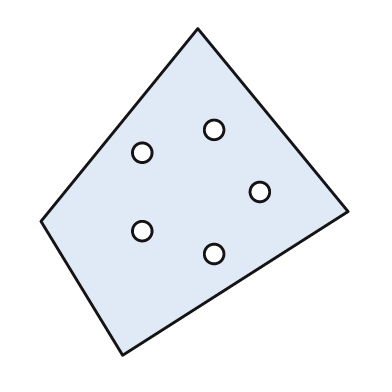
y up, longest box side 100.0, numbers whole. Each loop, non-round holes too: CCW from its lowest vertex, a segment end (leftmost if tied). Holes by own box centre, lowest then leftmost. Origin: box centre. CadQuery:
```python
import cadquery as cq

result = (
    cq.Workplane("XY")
    .moveTo(-22.0, -50.0)
    .lineTo(47.0, -6.0)
    .lineTo(1.0, 50.0)
    .lineTo(-47.0, -9.0)
    .close()
    .moveTo(6.0, -19.0)
    .circle(3.0)
    .moveTo(-16.0, -12.0)
    .circle(3.0)
    .moveTo(20.0, 0.0)
    .circle(3.0)
    .moveTo(-16.0, 12.0)
    .circle(3.0)
    .moveTo(6.0, 19.0)
    .circle(3.0)
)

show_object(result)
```